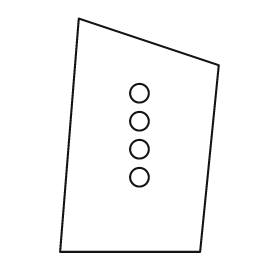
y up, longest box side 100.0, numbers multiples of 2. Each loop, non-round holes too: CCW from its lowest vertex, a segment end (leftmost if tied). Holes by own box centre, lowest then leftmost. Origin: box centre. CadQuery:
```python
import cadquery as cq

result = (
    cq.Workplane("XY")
    .moveTo(-34.0, -50.0)
    .lineTo(26.0, -50.0)
    .lineTo(34.0, 30.0)
    .lineTo(-26.0, 50.0)
    .close()
    .moveTo(0.0, -18.0)
    .circle(4.0)
    .moveTo(0.0, -6.0)
    .circle(4.0)
    .moveTo(0.0, 6.0)
    .circle(4.0)
    .moveTo(0.0, 18.0)
    .circle(4.0)
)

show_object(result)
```